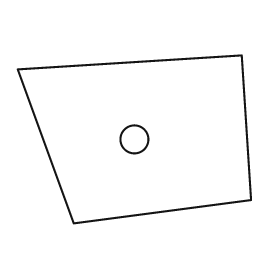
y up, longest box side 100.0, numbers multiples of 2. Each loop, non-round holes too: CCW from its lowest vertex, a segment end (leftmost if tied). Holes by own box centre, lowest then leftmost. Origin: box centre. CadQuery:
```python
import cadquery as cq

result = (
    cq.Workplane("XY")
    .moveTo(-26.0, -36.0)
    .lineTo(50.0, -26.0)
    .lineTo(46.0, 36.0)
    .lineTo(-50.0, 30.0)
    .close()
    .moveTo(0.0, 0.0)
    .circle(6.0)
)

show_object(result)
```